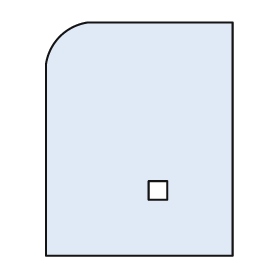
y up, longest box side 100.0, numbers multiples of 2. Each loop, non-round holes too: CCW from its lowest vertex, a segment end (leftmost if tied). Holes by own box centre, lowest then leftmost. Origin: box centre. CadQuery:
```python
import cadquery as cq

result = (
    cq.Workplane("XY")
    .moveTo(-40.0, -50.0)
    .lineTo(40.0, -50.0)
    .lineTo(40.0, 50.0)
    .lineTo(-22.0, 50.0)
    .threePointArc((-34.0, 44.0), (-40.0, 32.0))
    .close()
    .moveTo(4.0, -26.0)
    .lineTo(12.0, -26.0)
    .lineTo(12.0, -18.0)
    .lineTo(4.0, -18.0)
    .close()
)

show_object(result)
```